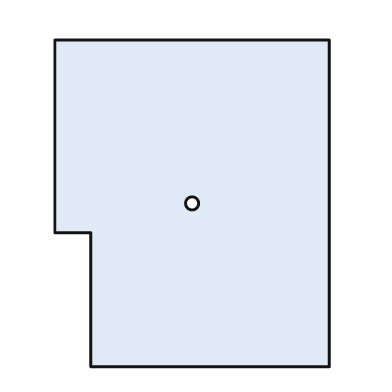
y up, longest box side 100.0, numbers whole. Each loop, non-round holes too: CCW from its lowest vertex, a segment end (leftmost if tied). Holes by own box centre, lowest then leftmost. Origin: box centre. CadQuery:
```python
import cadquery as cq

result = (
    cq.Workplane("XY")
    .moveTo(-31.0, -50.0)
    .lineTo(42.0, -50.0)
    .lineTo(42.0, 50.0)
    .lineTo(-42.0, 50.0)
    .lineTo(-42.0, -9.0)
    .lineTo(-31.0, -9.0)
    .close()
    .moveTo(0.0, 0.0)
    .circle(2.0)
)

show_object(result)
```